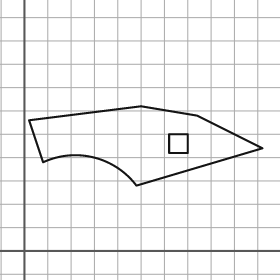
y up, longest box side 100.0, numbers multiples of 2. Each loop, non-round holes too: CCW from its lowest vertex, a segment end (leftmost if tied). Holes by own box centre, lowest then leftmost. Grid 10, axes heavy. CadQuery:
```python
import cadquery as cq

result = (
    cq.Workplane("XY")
    .moveTo(48.0, 28.0)
    .lineTo(102.0, 44.0)
    .lineTo(74.0, 58.0)
    .lineTo(50.0, 62.0)
    .lineTo(2.0, 56.0)
    .lineTo(8.0, 38.0)
    .threePointArc((30.0, 40.0), (48.0, 28.0))
    .close()
    .moveTo(62.0, 42.0)
    .lineTo(70.0, 42.0)
    .lineTo(70.0, 50.0)
    .lineTo(62.0, 50.0)
    .close()
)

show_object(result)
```